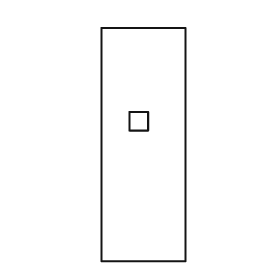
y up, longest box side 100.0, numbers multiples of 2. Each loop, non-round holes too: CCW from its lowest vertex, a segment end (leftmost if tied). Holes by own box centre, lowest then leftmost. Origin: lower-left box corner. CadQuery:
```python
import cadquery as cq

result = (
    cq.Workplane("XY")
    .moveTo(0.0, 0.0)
    .lineTo(36.0, 0.0)
    .lineTo(36.0, 100.0)
    .lineTo(0.0, 100.0)
    .close()
    .moveTo(12.0, 56.0)
    .lineTo(20.0, 56.0)
    .lineTo(20.0, 64.0)
    .lineTo(12.0, 64.0)
    .close()
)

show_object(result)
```